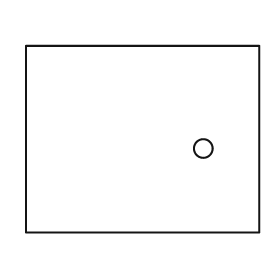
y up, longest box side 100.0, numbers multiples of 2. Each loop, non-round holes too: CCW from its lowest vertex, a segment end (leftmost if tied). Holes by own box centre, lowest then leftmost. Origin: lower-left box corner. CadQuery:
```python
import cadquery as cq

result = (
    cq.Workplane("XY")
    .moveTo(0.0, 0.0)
    .lineTo(100.0, 0.0)
    .lineTo(100.0, 80.0)
    .lineTo(0.0, 80.0)
    .close()
    .moveTo(76.0, 36.0)
    .circle(4.0)
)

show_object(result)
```